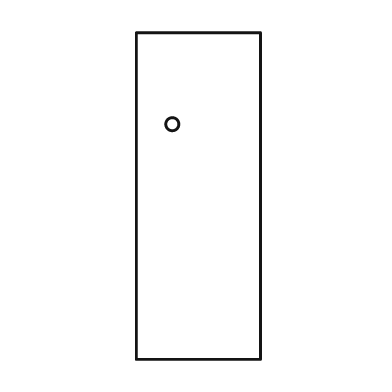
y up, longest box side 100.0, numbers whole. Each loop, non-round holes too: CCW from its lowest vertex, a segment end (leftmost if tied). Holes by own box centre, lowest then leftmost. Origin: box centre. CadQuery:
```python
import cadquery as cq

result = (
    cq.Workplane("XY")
    .moveTo(-19.0, -50.0)
    .lineTo(19.0, -50.0)
    .lineTo(19.0, 50.0)
    .lineTo(-19.0, 50.0)
    .close()
    .moveTo(-8.0, 22.0)
    .circle(2.0)
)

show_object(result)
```